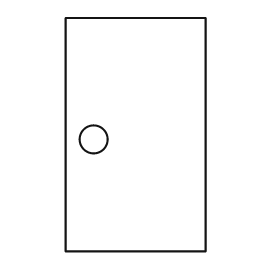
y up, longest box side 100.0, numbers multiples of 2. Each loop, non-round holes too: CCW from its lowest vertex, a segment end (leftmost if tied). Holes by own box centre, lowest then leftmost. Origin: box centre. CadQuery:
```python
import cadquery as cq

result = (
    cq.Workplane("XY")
    .moveTo(-30.0, -50.0)
    .lineTo(30.0, -50.0)
    .lineTo(30.0, 50.0)
    .lineTo(-30.0, 50.0)
    .close()
    .moveTo(-18.0, -2.0)
    .circle(6.0)
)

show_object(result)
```